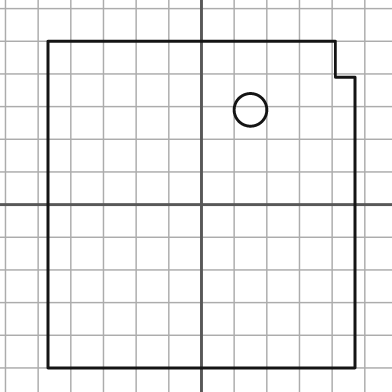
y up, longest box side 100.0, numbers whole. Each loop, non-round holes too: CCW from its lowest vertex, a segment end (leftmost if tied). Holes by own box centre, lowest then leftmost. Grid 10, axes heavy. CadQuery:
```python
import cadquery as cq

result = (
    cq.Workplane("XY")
    .moveTo(-47.0, -50.0)
    .lineTo(47.0, -50.0)
    .lineTo(47.0, 39.0)
    .lineTo(41.0, 39.0)
    .lineTo(41.0, 50.0)
    .lineTo(-47.0, 50.0)
    .close()
    .moveTo(15.0, 29.0)
    .circle(5.0)
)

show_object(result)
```